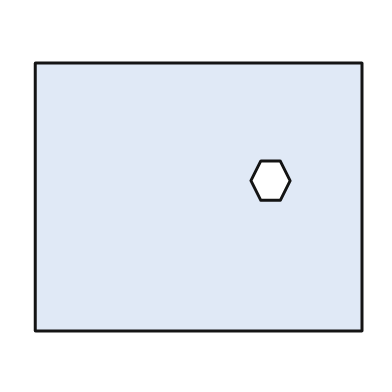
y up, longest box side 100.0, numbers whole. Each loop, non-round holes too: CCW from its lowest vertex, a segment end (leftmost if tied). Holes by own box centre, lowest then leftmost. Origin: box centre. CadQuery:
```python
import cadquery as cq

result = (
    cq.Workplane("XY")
    .moveTo(-50.0, -41.0)
    .lineTo(50.0, -41.0)
    .lineTo(50.0, 41.0)
    .lineTo(-50.0, 41.0)
    .close()
    .moveTo(19.0, -1.0)
    .lineTo(25.0, -1.0)
    .lineTo(28.0, 5.0)
    .lineTo(25.0, 11.0)
    .lineTo(19.0, 11.0)
    .lineTo(16.0, 5.0)
    .close()
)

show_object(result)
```